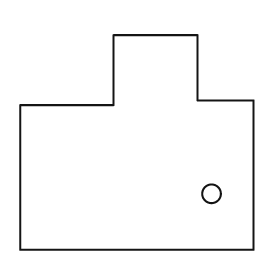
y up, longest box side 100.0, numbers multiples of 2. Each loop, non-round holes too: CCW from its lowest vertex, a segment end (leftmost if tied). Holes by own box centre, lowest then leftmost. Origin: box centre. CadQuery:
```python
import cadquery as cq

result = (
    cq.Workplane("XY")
    .moveTo(-50.0, -46.0)
    .lineTo(50.0, -46.0)
    .lineTo(50.0, 18.0)
    .lineTo(26.0, 18.0)
    .lineTo(26.0, 46.0)
    .lineTo(-10.0, 46.0)
    .lineTo(-10.0, 16.0)
    .lineTo(-50.0, 16.0)
    .close()
    .moveTo(32.0, -22.0)
    .circle(4.0)
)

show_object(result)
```